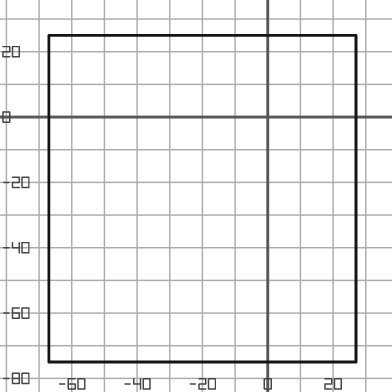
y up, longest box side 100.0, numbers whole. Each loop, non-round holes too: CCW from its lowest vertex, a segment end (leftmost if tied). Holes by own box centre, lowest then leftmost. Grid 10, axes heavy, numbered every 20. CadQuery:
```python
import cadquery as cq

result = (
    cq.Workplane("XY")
    .moveTo(-67.0, -75.0)
    .lineTo(27.0, -75.0)
    .lineTo(27.0, 25.0)
    .lineTo(-67.0, 25.0)
    .close()
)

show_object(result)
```